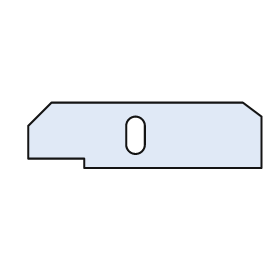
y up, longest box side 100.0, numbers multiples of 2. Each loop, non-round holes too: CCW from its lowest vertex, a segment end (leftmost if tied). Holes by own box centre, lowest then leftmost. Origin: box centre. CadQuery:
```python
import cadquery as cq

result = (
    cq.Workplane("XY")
    .moveTo(-26.0, -14.0)
    .lineTo(50.0, -14.0)
    .lineTo(50.0, 8.0)
    .lineTo(42.0, 14.0)
    .lineTo(-40.0, 14.0)
    .lineTo(-50.0, 4.0)
    .lineTo(-50.0, -10.0)
    .lineTo(-26.0, -10.0)
    .close()
    .moveTo(-8.0, -4.0)
    .threePointArc((-4.0, -8.0), (0.0, -4.0))
    .lineTo(0.0, 4.0)
    .threePointArc((-4.0, 8.0), (-8.0, 4.0))
    .close()
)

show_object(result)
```